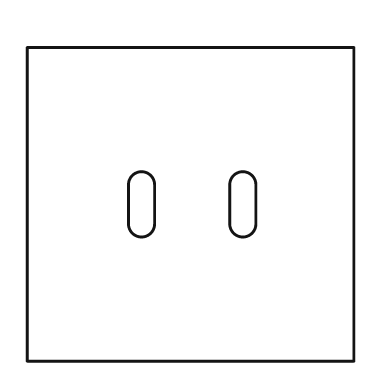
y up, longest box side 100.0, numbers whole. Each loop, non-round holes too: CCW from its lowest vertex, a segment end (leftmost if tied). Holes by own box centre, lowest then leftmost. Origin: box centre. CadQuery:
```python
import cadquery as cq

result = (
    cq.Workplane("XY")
    .moveTo(-50.0, -48.0)
    .lineTo(50.0, -48.0)
    .lineTo(50.0, 48.0)
    .lineTo(-50.0, 48.0)
    .close()
    .moveTo(-19.0, -6.0)
    .threePointArc((-15.0, -10.0), (-11.0, -6.0))
    .lineTo(-11.0, 6.0)
    .threePointArc((-15.0, 10.0), (-19.0, 6.0))
    .close()
    .moveTo(12.0, -6.0)
    .threePointArc((16.0, -10.0), (20.0, -6.0))
    .lineTo(20.0, 6.0)
    .threePointArc((16.0, 10.0), (12.0, 6.0))
    .close()
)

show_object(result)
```